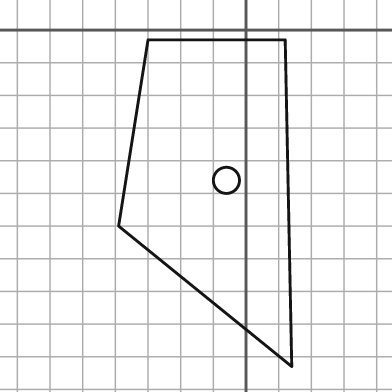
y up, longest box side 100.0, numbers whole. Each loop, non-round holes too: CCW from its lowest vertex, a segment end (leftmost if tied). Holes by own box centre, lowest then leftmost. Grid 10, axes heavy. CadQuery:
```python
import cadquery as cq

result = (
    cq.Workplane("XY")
    .moveTo(14.0, -103.0)
    .lineTo(12.0, -3.0)
    .lineTo(-30.0, -3.0)
    .lineTo(-39.0, -60.0)
    .close()
    .moveTo(-6.0, -46.0)
    .circle(4.0)
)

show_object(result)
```